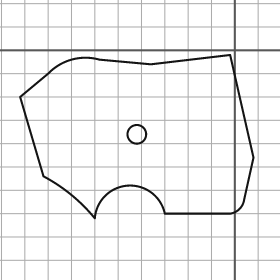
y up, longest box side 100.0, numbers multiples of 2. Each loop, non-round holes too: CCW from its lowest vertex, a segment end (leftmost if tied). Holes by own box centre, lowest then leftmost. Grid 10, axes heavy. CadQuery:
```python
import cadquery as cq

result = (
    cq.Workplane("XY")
    .moveTo(-60.0, -72.0)
    .threePointArc((-46.0, -58.0), (-30.0, -70.0))
    .lineTo(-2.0, -70.0)
    .threePointArc((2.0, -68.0), (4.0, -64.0))
    .lineTo(8.0, -46.0)
    .lineTo(-2.0, -2.0)
    .lineTo(-36.0, -6.0)
    .lineTo(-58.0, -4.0)
    .threePointArc((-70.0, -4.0), (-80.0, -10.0))
    .lineTo(-92.0, -20.0)
    .lineTo(-82.0, -54.0)
    .threePointArc((-70.0, -62.0), (-60.0, -72.0))
    .close()
    .moveTo(-42.0, -36.0)
    .circle(4.0)
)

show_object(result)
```